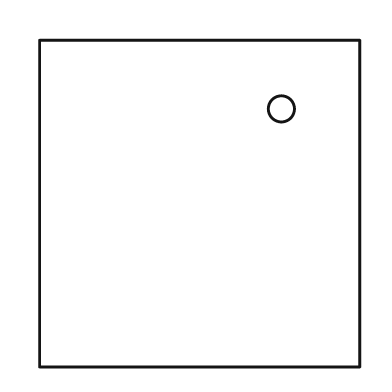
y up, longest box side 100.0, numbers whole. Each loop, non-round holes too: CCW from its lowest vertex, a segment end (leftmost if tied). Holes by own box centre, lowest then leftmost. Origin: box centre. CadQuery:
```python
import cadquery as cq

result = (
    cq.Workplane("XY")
    .moveTo(-49.0, -50.0)
    .lineTo(49.0, -50.0)
    .lineTo(49.0, 50.0)
    .lineTo(-49.0, 50.0)
    .close()
    .moveTo(25.0, 29.0)
    .circle(4.0)
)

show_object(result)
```